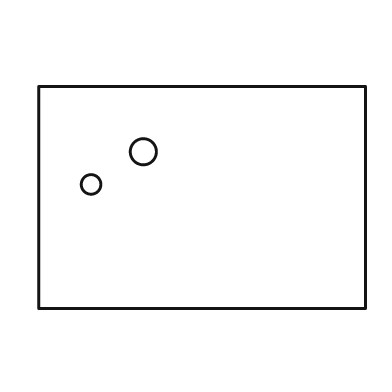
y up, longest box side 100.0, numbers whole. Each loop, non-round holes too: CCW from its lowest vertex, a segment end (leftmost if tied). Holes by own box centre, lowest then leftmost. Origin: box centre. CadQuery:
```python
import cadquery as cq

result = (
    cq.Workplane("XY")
    .moveTo(-50.0, -34.0)
    .lineTo(50.0, -34.0)
    .lineTo(50.0, 34.0)
    .lineTo(-50.0, 34.0)
    .close()
    .moveTo(-34.0, 4.0)
    .circle(3.0)
    .moveTo(-18.0, 14.0)
    .circle(4.0)
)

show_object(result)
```